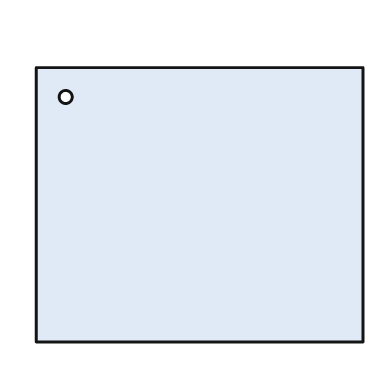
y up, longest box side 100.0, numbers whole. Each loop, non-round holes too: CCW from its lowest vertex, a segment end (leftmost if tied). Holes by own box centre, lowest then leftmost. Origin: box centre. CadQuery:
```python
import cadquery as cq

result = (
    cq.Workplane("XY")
    .moveTo(-50.0, -42.0)
    .lineTo(50.0, -42.0)
    .lineTo(50.0, 42.0)
    .lineTo(-50.0, 42.0)
    .close()
    .moveTo(-41.0, 33.0)
    .circle(2.0)
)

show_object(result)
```